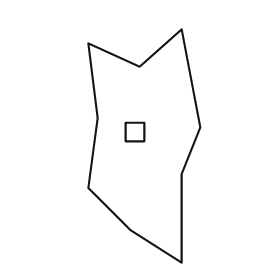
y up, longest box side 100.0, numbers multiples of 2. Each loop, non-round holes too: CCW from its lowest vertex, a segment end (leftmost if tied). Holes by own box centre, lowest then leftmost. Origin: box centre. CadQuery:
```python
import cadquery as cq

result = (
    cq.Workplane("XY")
    .moveTo(16.0, -50.0)
    .lineTo(16.0, -12.0)
    .lineTo(24.0, 8.0)
    .lineTo(16.0, 50.0)
    .lineTo(-2.0, 34.0)
    .lineTo(-24.0, 44.0)
    .lineTo(-20.0, 12.0)
    .lineTo(-24.0, -18.0)
    .lineTo(-6.0, -36.0)
    .close()
    .moveTo(-8.0, 2.0)
    .lineTo(0.0, 2.0)
    .lineTo(0.0, 10.0)
    .lineTo(-8.0, 10.0)
    .close()
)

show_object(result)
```